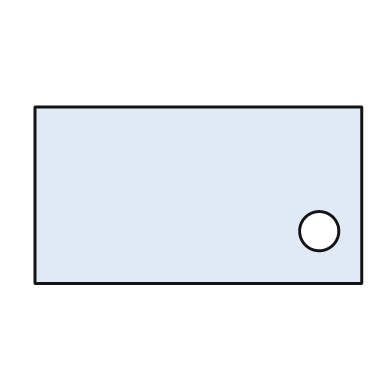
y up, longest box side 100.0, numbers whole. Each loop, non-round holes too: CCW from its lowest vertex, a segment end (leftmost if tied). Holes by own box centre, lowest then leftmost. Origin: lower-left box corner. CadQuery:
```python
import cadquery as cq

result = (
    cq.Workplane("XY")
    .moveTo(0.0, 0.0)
    .lineTo(100.0, 0.0)
    .lineTo(100.0, 54.0)
    .lineTo(0.0, 54.0)
    .close()
    .moveTo(87.0, 16.0)
    .circle(6.0)
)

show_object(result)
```